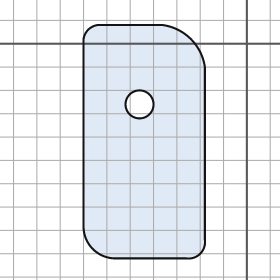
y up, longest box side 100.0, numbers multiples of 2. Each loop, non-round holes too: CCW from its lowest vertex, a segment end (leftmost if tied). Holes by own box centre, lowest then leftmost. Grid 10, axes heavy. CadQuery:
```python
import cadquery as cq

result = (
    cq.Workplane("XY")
    .moveTo(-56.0, -92.0)
    .lineTo(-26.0, -92.0)
    .threePointArc((-20.0, -90.0), (-18.0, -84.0))
    .lineTo(-18.0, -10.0)
    .threePointArc((-24.0, 2.0), (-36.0, 8.0))
    .lineTo(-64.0, 8.0)
    .threePointArc((-68.0, 6.0), (-70.0, 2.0))
    .lineTo(-70.0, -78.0)
    .threePointArc((-66.0, -88.0), (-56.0, -92.0))
    .close()
    .moveTo(-46.0, -26.0)
    .circle(6.0)
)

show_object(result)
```